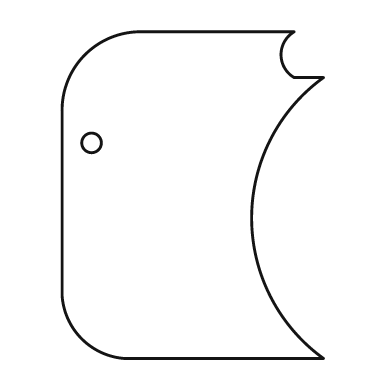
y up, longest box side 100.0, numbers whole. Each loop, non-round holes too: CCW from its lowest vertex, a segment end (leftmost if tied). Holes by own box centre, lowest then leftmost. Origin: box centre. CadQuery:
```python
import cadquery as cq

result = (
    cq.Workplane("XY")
    .moveTo(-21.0, -50.0)
    .lineTo(40.0, -50.0)
    .threePointArc((18.0, -7.0), (40.0, 36.0))
    .lineTo(31.0, 36.0)
    .threePointArc((27.0, 43.0), (31.0, 50.0))
    .lineTo(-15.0, 50.0)
    .threePointArc((-33.0, 43.0), (-40.0, 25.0))
    .lineTo(-40.0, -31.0)
    .threePointArc((-34.0, -44.0), (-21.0, -50.0))
    .close()
    .moveTo(-31.0, 16.0)
    .circle(3.0)
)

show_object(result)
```